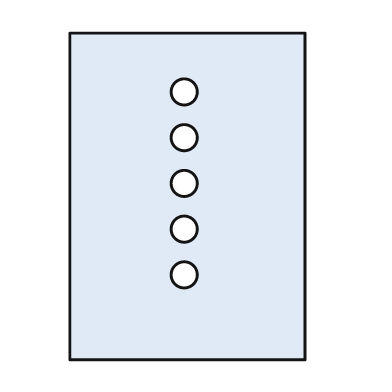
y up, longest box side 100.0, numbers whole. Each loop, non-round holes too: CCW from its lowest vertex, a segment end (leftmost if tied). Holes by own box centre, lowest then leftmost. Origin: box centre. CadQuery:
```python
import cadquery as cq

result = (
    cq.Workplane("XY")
    .moveTo(-36.0, -50.0)
    .lineTo(36.0, -50.0)
    .lineTo(36.0, 50.0)
    .lineTo(-36.0, 50.0)
    .close()
    .moveTo(-1.0, -24.0)
    .circle(4.0)
    .moveTo(-1.0, -10.0)
    .circle(4.0)
    .moveTo(-1.0, 4.0)
    .circle(4.0)
    .moveTo(-1.0, 18.0)
    .circle(4.0)
    .moveTo(-1.0, 32.0)
    .circle(4.0)
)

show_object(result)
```